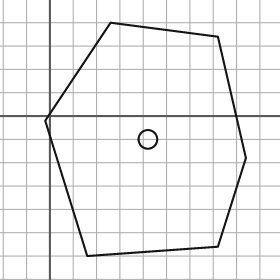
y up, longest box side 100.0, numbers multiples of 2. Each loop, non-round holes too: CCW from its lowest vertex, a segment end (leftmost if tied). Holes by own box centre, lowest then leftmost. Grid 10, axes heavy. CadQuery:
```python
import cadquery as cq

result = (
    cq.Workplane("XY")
    .moveTo(16.0, -60.0)
    .lineTo(72.0, -56.0)
    .lineTo(84.0, -18.0)
    .lineTo(72.0, 34.0)
    .lineTo(26.0, 40.0)
    .lineTo(-2.0, -2.0)
    .close()
    .moveTo(42.0, -10.0)
    .circle(4.0)
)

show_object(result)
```